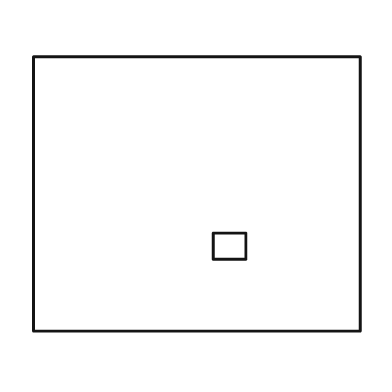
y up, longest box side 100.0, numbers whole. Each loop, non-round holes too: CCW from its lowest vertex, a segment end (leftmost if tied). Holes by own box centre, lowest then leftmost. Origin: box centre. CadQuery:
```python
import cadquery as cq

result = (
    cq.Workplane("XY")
    .moveTo(-50.0, -42.0)
    .lineTo(50.0, -42.0)
    .lineTo(50.0, 42.0)
    .lineTo(-50.0, 42.0)
    .close()
    .moveTo(5.0, -20.0)
    .lineTo(15.0, -20.0)
    .lineTo(15.0, -12.0)
    .lineTo(5.0, -12.0)
    .close()
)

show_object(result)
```